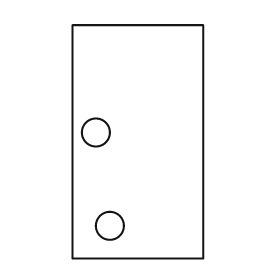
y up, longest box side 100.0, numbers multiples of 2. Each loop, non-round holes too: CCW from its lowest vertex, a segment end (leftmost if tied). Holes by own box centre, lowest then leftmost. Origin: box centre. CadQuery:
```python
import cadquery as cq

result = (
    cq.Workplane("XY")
    .moveTo(-28.0, -50.0)
    .lineTo(28.0, -50.0)
    .lineTo(28.0, 50.0)
    .lineTo(-28.0, 50.0)
    .close()
    .moveTo(-12.0, -36.0)
    .circle(6.0)
    .moveTo(-18.0, 4.0)
    .circle(6.0)
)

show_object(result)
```